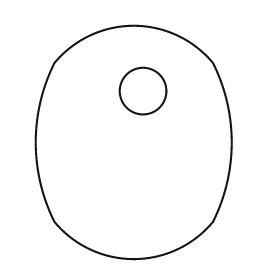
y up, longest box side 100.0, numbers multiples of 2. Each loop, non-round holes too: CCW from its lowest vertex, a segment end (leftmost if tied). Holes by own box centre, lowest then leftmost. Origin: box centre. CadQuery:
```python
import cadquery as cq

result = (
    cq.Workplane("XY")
    .moveTo(-34.0, -34.0)
    .threePointArc((0.0, -50.0), (34.0, -34.0))
    .threePointArc((42.0, 0.0), (34.0, 34.0))
    .threePointArc((0.0, 50.0), (-34.0, 34.0))
    .threePointArc((-42.0, 0.0), (-34.0, -34.0))
    .close()
    .moveTo(4.0, 22.0)
    .circle(10.0)
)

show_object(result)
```